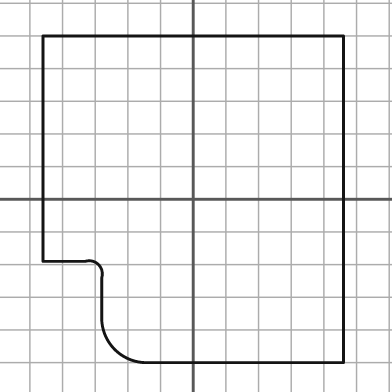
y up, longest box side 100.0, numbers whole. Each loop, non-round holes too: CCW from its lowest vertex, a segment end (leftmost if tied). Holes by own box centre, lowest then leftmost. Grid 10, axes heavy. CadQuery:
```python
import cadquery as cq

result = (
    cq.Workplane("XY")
    .moveTo(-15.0, -50.0)
    .lineTo(46.0, -50.0)
    .lineTo(46.0, 50.0)
    .lineTo(-46.0, 50.0)
    .lineTo(-46.0, -19.0)
    .lineTo(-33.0, -19.0)
    .threePointArc((-29.0, -20.0), (-28.0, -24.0))
    .lineTo(-28.0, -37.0)
    .threePointArc((-24.0, -46.0), (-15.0, -50.0))
    .close()
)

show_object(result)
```